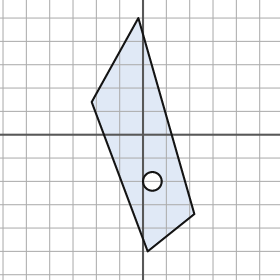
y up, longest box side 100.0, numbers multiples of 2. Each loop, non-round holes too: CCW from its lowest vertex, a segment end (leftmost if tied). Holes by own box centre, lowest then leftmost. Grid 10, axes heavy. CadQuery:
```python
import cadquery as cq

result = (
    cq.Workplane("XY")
    .moveTo(2.0, -50.0)
    .lineTo(22.0, -34.0)
    .lineTo(-2.0, 50.0)
    .lineTo(-22.0, 14.0)
    .close()
    .moveTo(4.0, -20.0)
    .circle(4.0)
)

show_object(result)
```